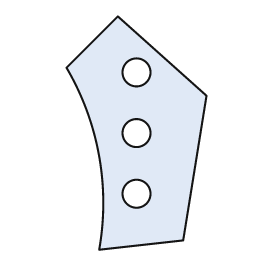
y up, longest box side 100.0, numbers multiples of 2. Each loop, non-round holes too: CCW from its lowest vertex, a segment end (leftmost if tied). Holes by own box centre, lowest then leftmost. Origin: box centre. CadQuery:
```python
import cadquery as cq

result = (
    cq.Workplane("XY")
    .moveTo(-16.0, -50.0)
    .lineTo(20.0, -46.0)
    .lineTo(30.0, 16.0)
    .lineTo(-8.0, 50.0)
    .lineTo(-30.0, 28.0)
    .threePointArc((-16.0, -10.0), (-16.0, -50.0))
    .close()
    .moveTo(0.0, -26.0)
    .circle(6.0)
    .moveTo(0.0, 0.0)
    .circle(6.0)
    .moveTo(0.0, 26.0)
    .circle(6.0)
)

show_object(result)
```